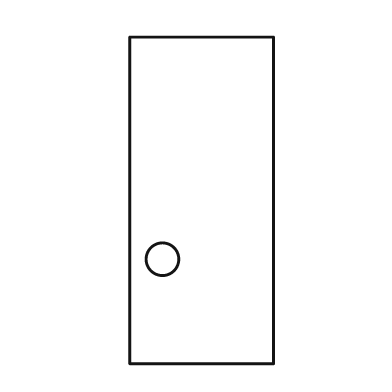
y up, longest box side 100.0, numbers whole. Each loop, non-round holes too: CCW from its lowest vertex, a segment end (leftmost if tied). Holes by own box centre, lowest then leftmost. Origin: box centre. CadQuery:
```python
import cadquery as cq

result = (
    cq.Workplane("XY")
    .moveTo(-22.0, -50.0)
    .lineTo(22.0, -50.0)
    .lineTo(22.0, 50.0)
    .lineTo(-22.0, 50.0)
    .close()
    .moveTo(-12.0, -18.0)
    .circle(5.0)
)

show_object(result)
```